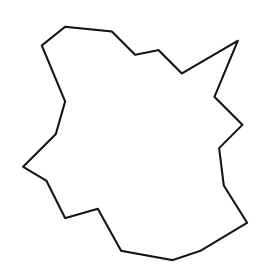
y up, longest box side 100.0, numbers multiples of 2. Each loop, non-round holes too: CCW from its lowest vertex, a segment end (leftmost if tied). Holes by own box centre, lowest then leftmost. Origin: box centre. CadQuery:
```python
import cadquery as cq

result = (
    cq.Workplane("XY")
    .moveTo(16.0, -50.0)
    .lineTo(28.0, -46.0)
    .lineTo(48.0, -34.0)
    .lineTo(38.0, -18.0)
    .lineTo(36.0, -2.0)
    .lineTo(46.0, 8.0)
    .lineTo(34.0, 20.0)
    .lineTo(44.0, 44.0)
    .lineTo(20.0, 30.0)
    .lineTo(10.0, 40.0)
    .lineTo(0.0, 38.0)
    .lineTo(-10.0, 48.0)
    .lineTo(-30.0, 50.0)
    .lineTo(-40.0, 42.0)
    .lineTo(-30.0, 18.0)
    .lineTo(-34.0, 4.0)
    .lineTo(-48.0, -10.0)
    .lineTo(-38.0, -16.0)
    .lineTo(-30.0, -32.0)
    .lineTo(-16.0, -28.0)
    .lineTo(-6.0, -46.0)
    .close()
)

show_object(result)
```